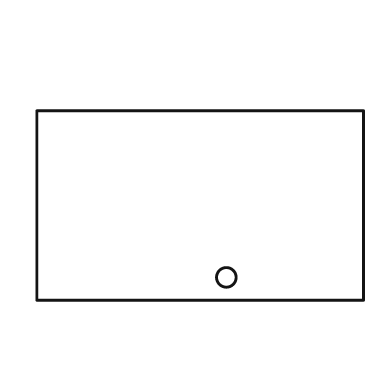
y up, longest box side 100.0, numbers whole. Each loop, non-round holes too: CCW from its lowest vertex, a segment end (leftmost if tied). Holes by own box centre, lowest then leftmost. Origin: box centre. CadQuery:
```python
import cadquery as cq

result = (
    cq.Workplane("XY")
    .moveTo(-50.0, -29.0)
    .lineTo(50.0, -29.0)
    .lineTo(50.0, 29.0)
    .lineTo(-50.0, 29.0)
    .close()
    .moveTo(8.0, -22.0)
    .circle(3.0)
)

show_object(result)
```